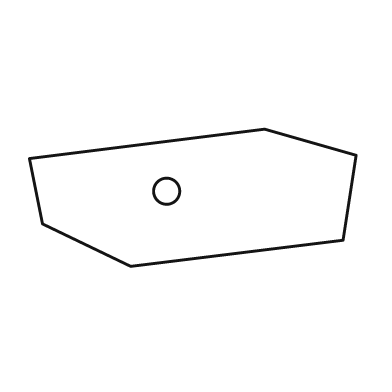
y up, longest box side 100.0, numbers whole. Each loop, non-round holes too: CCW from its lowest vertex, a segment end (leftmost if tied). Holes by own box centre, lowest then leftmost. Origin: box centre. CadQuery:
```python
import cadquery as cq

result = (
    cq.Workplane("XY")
    .moveTo(-19.0, -21.0)
    .lineTo(46.0, -13.0)
    .lineTo(50.0, 13.0)
    .lineTo(22.0, 21.0)
    .lineTo(-50.0, 12.0)
    .lineTo(-46.0, -8.0)
    .close()
    .moveTo(-8.0, 2.0)
    .circle(4.0)
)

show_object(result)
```